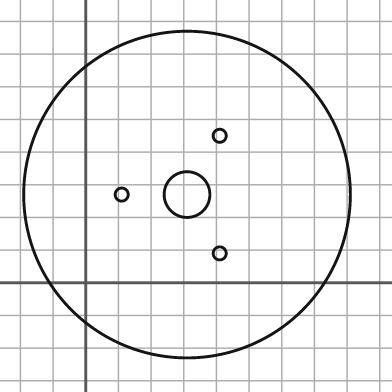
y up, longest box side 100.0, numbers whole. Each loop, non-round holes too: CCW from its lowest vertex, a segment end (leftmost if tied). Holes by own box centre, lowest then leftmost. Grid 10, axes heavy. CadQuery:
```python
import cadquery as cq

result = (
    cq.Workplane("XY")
    .moveTo(31.0, 27.0)
    .circle(50.0)
    .moveTo(41.0, 9.0)
    .circle(2.0)
    .moveTo(11.0, 27.0)
    .circle(2.0)
    .moveTo(31.0, 27.0)
    .circle(7.0)
    .moveTo(41.0, 45.0)
    .circle(2.0)
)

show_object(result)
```